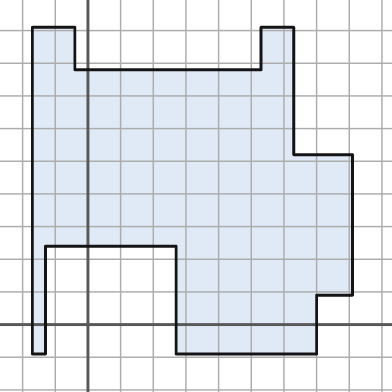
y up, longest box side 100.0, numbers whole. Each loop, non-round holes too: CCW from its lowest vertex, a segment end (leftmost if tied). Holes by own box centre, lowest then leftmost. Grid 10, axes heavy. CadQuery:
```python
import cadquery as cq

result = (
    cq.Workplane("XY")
    .moveTo(-17.0, -9.0)
    .lineTo(-13.0, -9.0)
    .lineTo(-13.0, 24.0)
    .lineTo(27.0, 24.0)
    .lineTo(27.0, -9.0)
    .lineTo(70.0, -9.0)
    .lineTo(70.0, 9.0)
    .lineTo(81.0, 9.0)
    .lineTo(81.0, 52.0)
    .lineTo(63.0, 52.0)
    .lineTo(63.0, 91.0)
    .lineTo(53.0, 91.0)
    .lineTo(53.0, 78.0)
    .lineTo(-4.0, 78.0)
    .lineTo(-4.0, 91.0)
    .lineTo(-17.0, 91.0)
    .close()
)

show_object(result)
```